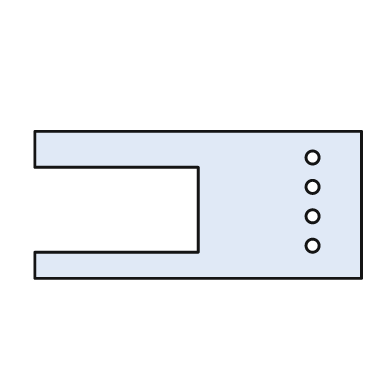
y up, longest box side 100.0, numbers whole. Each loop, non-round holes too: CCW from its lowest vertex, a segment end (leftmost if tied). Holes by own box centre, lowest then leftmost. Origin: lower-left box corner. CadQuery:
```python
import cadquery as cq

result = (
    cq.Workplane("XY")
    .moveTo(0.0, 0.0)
    .lineTo(100.0, 0.0)
    .lineTo(100.0, 45.0)
    .lineTo(0.0, 45.0)
    .lineTo(0.0, 34.0)
    .lineTo(50.0, 34.0)
    .lineTo(50.0, 8.0)
    .lineTo(0.0, 8.0)
    .close()
    .moveTo(85.0, 10.0)
    .circle(2.0)
    .moveTo(85.0, 19.0)
    .circle(2.0)
    .moveTo(85.0, 28.0)
    .circle(2.0)
    .moveTo(85.0, 37.0)
    .circle(2.0)
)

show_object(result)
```